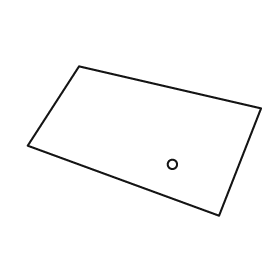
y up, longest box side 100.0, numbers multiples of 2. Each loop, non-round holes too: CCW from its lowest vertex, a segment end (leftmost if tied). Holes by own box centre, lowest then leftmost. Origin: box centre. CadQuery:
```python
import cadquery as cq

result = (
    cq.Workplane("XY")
    .moveTo(32.0, -32.0)
    .lineTo(50.0, 14.0)
    .lineTo(-28.0, 32.0)
    .lineTo(-50.0, -2.0)
    .close()
    .moveTo(12.0, -10.0)
    .circle(2.0)
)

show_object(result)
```